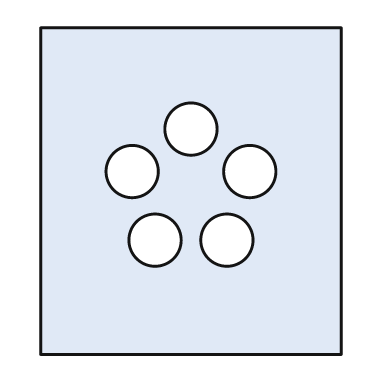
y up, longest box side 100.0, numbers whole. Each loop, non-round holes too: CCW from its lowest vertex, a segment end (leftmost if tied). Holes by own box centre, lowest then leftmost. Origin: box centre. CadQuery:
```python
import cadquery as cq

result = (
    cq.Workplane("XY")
    .moveTo(-46.0, -50.0)
    .lineTo(46.0, -50.0)
    .lineTo(46.0, 50.0)
    .lineTo(-46.0, 50.0)
    .close()
    .moveTo(-11.0, -15.0)
    .circle(8.0)
    .moveTo(11.0, -15.0)
    .circle(8.0)
    .moveTo(-18.0, 6.0)
    .circle(8.0)
    .moveTo(18.0, 6.0)
    .circle(8.0)
    .moveTo(0.0, 19.0)
    .circle(8.0)
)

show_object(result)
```